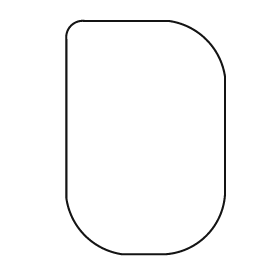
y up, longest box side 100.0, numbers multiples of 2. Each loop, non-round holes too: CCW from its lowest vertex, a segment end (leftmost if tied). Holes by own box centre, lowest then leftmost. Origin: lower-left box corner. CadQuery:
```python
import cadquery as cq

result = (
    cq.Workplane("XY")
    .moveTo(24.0, 0.0)
    .lineTo(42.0, 0.0)
    .threePointArc((60.0, 8.0), (68.0, 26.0))
    .lineTo(68.0, 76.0)
    .threePointArc((60.0, 92.0), (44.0, 100.0))
    .lineTo(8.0, 100.0)
    .threePointArc((2.0, 98.0), (0.0, 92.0))
    .lineTo(0.0, 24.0)
    .threePointArc((8.0, 8.0), (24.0, 0.0))
    .close()
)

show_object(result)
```